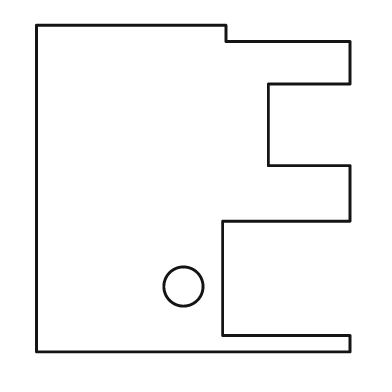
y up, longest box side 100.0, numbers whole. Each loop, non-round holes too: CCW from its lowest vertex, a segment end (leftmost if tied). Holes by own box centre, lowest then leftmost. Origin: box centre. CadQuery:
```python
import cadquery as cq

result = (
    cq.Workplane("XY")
    .moveTo(-48.0, -50.0)
    .lineTo(48.0, -50.0)
    .lineTo(48.0, -45.0)
    .lineTo(9.0, -45.0)
    .lineTo(9.0, -10.0)
    .lineTo(48.0, -10.0)
    .lineTo(48.0, 7.0)
    .lineTo(23.0, 7.0)
    .lineTo(23.0, 32.0)
    .lineTo(48.0, 32.0)
    .lineTo(48.0, 45.0)
    .lineTo(10.0, 45.0)
    .lineTo(10.0, 50.0)
    .lineTo(-48.0, 50.0)
    .close()
    .moveTo(-3.0, -30.0)
    .circle(6.0)
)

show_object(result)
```